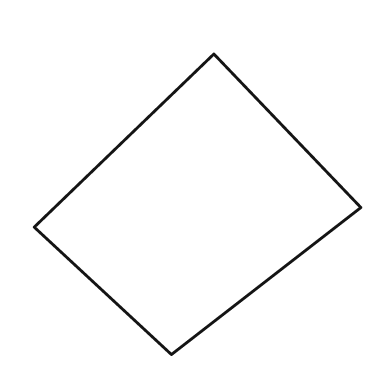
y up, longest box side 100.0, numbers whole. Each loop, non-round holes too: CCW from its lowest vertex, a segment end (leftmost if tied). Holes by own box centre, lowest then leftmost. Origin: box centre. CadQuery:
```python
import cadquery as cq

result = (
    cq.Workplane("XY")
    .moveTo(-8.0, -46.0)
    .lineTo(50.0, -1.0)
    .lineTo(5.0, 46.0)
    .lineTo(-50.0, -7.0)
    .close()
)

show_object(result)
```